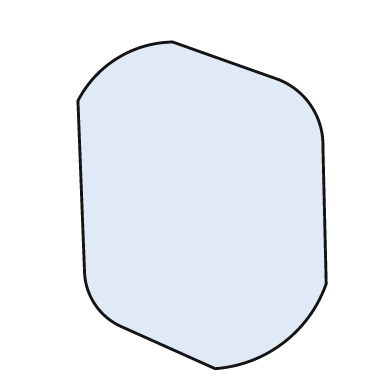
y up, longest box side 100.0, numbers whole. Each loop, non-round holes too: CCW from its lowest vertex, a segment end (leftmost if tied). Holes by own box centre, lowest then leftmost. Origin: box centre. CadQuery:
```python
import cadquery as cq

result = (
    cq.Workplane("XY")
    .moveTo(4.0, -50.0)
    .threePointArc((25.0, -42.0), (38.0, -24.0))
    .lineTo(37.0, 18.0)
    .threePointArc((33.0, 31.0), (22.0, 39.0))
    .lineTo(-9.0, 50.0)
    .threePointArc((-26.0, 45.0), (-38.0, 32.0))
    .lineTo(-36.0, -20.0)
    .threePointArc((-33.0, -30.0), (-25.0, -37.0))
    .close()
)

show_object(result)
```